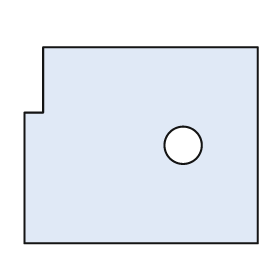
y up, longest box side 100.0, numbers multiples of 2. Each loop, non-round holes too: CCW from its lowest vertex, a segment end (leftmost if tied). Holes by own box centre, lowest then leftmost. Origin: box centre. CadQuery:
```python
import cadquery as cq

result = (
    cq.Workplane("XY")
    .moveTo(-50.0, -42.0)
    .lineTo(50.0, -42.0)
    .lineTo(50.0, 42.0)
    .lineTo(-42.0, 42.0)
    .lineTo(-42.0, 14.0)
    .lineTo(-50.0, 14.0)
    .close()
    .moveTo(18.0, 0.0)
    .circle(8.0)
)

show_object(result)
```